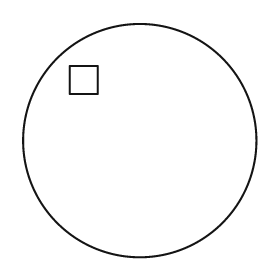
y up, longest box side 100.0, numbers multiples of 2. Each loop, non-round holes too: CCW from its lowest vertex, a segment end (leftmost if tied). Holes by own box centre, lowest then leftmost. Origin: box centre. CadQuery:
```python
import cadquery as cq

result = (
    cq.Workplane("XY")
    .moveTo(0.0, 0.0)
    .circle(50.0)
    .moveTo(-30.0, 20.0)
    .lineTo(-18.0, 20.0)
    .lineTo(-18.0, 32.0)
    .lineTo(-30.0, 32.0)
    .close()
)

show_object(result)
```